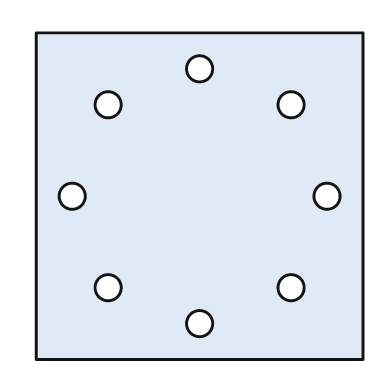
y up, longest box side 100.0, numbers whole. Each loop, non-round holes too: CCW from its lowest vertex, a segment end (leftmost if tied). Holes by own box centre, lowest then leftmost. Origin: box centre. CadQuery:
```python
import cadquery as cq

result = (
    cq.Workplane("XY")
    .moveTo(-50.0, -50.0)
    .lineTo(50.0, -50.0)
    .lineTo(50.0, 50.0)
    .lineTo(-50.0, 50.0)
    .close()
    .moveTo(0.0, -39.0)
    .circle(4.0)
    .moveTo(-28.0, -28.0)
    .circle(4.0)
    .moveTo(28.0, -28.0)
    .circle(4.0)
    .moveTo(-39.0, 0.0)
    .circle(4.0)
    .moveTo(39.0, 0.0)
    .circle(4.0)
    .moveTo(-28.0, 28.0)
    .circle(4.0)
    .moveTo(28.0, 28.0)
    .circle(4.0)
    .moveTo(0.0, 39.0)
    .circle(4.0)
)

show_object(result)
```